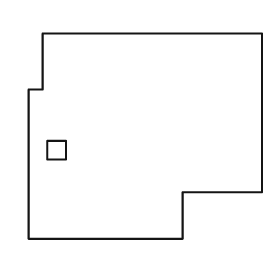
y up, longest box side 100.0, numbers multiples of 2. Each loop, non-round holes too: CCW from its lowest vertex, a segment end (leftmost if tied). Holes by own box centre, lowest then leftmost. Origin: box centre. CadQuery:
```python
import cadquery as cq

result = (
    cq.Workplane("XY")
    .moveTo(-50.0, -44.0)
    .lineTo(16.0, -44.0)
    .lineTo(16.0, -24.0)
    .lineTo(50.0, -24.0)
    .lineTo(50.0, 44.0)
    .lineTo(-44.0, 44.0)
    .lineTo(-44.0, 20.0)
    .lineTo(-50.0, 20.0)
    .close()
    .moveTo(-42.0, -10.0)
    .lineTo(-34.0, -10.0)
    .lineTo(-34.0, -2.0)
    .lineTo(-42.0, -2.0)
    .close()
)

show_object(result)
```